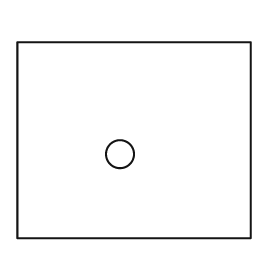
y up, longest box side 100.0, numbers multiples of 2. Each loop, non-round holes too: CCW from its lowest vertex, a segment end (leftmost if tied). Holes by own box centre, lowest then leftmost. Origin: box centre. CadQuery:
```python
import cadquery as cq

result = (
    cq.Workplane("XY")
    .moveTo(-50.0, -42.0)
    .lineTo(50.0, -42.0)
    .lineTo(50.0, 42.0)
    .lineTo(-50.0, 42.0)
    .close()
    .moveTo(-6.0, -6.0)
    .circle(6.0)
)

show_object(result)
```